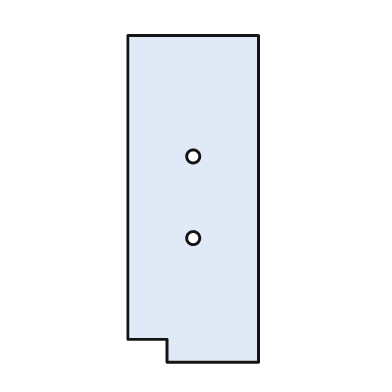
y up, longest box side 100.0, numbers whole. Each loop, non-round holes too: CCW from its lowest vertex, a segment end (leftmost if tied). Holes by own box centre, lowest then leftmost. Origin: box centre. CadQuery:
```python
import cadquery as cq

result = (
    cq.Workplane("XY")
    .moveTo(-8.0, -50.0)
    .lineTo(20.0, -50.0)
    .lineTo(20.0, 50.0)
    .lineTo(-20.0, 50.0)
    .lineTo(-20.0, -43.0)
    .lineTo(-8.0, -43.0)
    .close()
    .moveTo(0.0, -12.0)
    .circle(2.0)
    .moveTo(0.0, 13.0)
    .circle(2.0)
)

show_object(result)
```